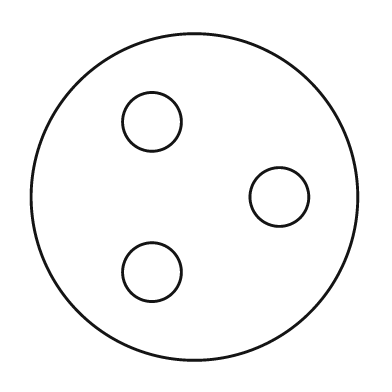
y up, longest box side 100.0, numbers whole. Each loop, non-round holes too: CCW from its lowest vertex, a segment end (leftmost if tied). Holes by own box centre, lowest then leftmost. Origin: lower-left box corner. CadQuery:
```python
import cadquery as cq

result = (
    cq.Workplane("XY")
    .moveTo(50.0, 50.0)
    .circle(50.0)
    .moveTo(37.0, 27.0)
    .circle(9.0)
    .moveTo(76.0, 50.0)
    .circle(9.0)
    .moveTo(37.0, 73.0)
    .circle(9.0)
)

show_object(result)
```